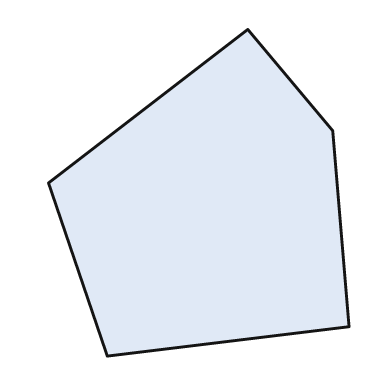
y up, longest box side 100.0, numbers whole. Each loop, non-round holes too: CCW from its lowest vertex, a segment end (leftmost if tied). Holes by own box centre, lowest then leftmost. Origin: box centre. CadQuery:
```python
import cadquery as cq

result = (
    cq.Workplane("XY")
    .moveTo(-28.0, -50.0)
    .lineTo(46.0, -41.0)
    .lineTo(41.0, 19.0)
    .lineTo(15.0, 50.0)
    .lineTo(-46.0, 3.0)
    .close()
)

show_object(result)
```